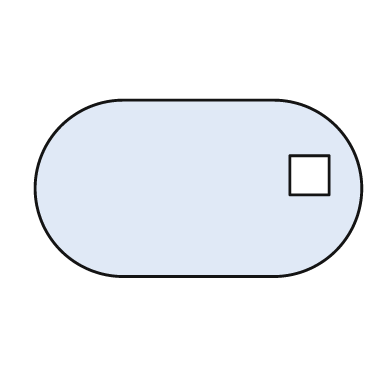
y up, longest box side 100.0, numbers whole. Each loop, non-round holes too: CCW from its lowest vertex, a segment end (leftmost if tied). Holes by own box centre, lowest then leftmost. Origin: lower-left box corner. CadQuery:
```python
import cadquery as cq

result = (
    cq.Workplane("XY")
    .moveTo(27.0, 0.0)
    .lineTo(73.0, 0.0)
    .threePointArc((100.0, 27.0), (73.0, 54.0))
    .lineTo(27.0, 54.0)
    .threePointArc((0.0, 27.0), (27.0, 0.0))
    .close()
    .moveTo(78.0, 25.0)
    .lineTo(90.0, 25.0)
    .lineTo(90.0, 37.0)
    .lineTo(78.0, 37.0)
    .close()
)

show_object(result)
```